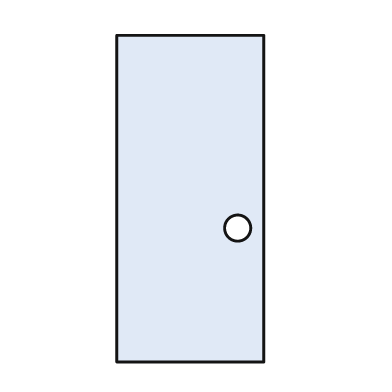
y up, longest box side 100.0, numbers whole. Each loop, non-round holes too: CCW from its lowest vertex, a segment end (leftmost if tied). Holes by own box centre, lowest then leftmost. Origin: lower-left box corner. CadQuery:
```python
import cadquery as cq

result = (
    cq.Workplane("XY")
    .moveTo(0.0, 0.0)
    .lineTo(45.0, 0.0)
    .lineTo(45.0, 100.0)
    .lineTo(0.0, 100.0)
    .close()
    .moveTo(37.0, 41.0)
    .circle(4.0)
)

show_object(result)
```